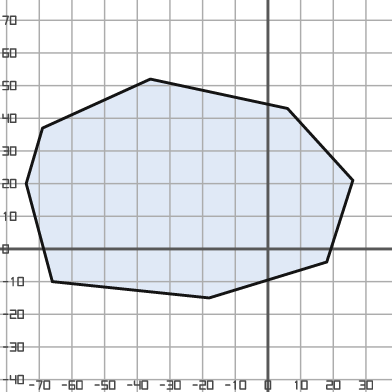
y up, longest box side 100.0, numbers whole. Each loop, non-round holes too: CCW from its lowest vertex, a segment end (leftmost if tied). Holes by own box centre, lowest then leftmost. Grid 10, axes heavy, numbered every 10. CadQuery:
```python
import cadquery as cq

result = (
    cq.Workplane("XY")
    .moveTo(-18.0, -15.0)
    .lineTo(18.0, -4.0)
    .lineTo(26.0, 21.0)
    .lineTo(6.0, 43.0)
    .lineTo(-36.0, 52.0)
    .lineTo(-69.0, 37.0)
    .lineTo(-74.0, 20.0)
    .lineTo(-66.0, -10.0)
    .close()
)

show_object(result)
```